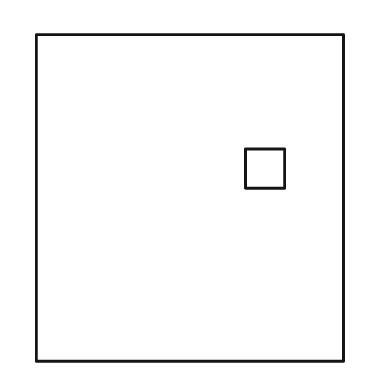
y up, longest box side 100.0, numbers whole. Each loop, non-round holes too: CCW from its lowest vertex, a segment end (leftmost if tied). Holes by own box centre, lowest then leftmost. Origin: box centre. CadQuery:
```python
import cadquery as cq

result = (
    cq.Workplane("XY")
    .moveTo(-47.0, -50.0)
    .lineTo(47.0, -50.0)
    .lineTo(47.0, 50.0)
    .lineTo(-47.0, 50.0)
    .close()
    .moveTo(17.0, 3.0)
    .lineTo(29.0, 3.0)
    .lineTo(29.0, 15.0)
    .lineTo(17.0, 15.0)
    .close()
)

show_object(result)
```